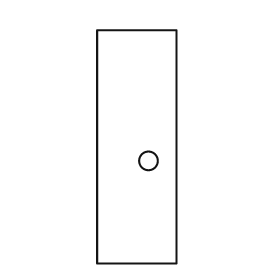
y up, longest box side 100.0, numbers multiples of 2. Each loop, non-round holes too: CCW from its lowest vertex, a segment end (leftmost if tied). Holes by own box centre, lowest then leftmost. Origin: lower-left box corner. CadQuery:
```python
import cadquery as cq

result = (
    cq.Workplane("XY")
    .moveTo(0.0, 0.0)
    .lineTo(34.0, 0.0)
    .lineTo(34.0, 100.0)
    .lineTo(0.0, 100.0)
    .close()
    .moveTo(22.0, 44.0)
    .circle(4.0)
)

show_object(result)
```